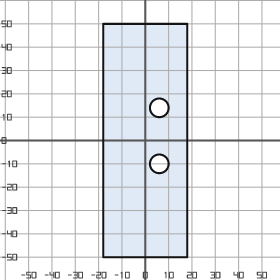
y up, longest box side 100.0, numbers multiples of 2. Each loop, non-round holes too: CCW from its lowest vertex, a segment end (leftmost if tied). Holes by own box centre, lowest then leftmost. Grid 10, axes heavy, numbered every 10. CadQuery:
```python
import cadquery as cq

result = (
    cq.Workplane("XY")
    .moveTo(-18.0, -50.0)
    .lineTo(18.0, -50.0)
    .lineTo(18.0, 50.0)
    .lineTo(-18.0, 50.0)
    .close()
    .moveTo(6.0, -10.0)
    .circle(4.0)
    .moveTo(6.0, 14.0)
    .circle(4.0)
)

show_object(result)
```